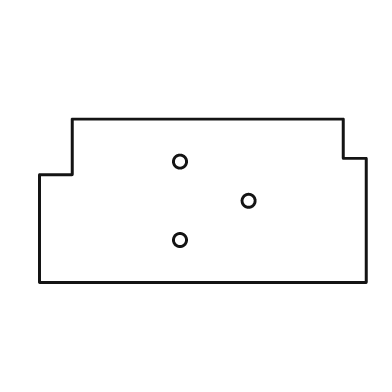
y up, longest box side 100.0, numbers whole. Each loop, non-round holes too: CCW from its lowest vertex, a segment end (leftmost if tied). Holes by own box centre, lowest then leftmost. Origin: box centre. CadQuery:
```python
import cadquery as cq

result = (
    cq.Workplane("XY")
    .moveTo(-50.0, -25.0)
    .lineTo(50.0, -25.0)
    .lineTo(50.0, 13.0)
    .lineTo(43.0, 13.0)
    .lineTo(43.0, 25.0)
    .lineTo(-40.0, 25.0)
    .lineTo(-40.0, 8.0)
    .lineTo(-50.0, 8.0)
    .close()
    .moveTo(-7.0, -12.0)
    .circle(2.0)
    .moveTo(14.0, 0.0)
    .circle(2.0)
    .moveTo(-7.0, 12.0)
    .circle(2.0)
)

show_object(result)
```